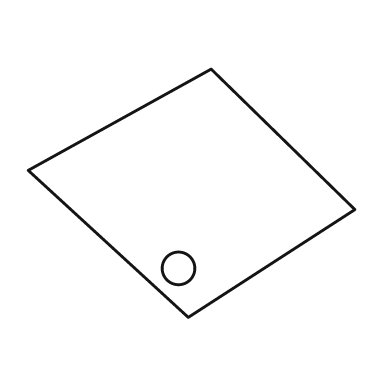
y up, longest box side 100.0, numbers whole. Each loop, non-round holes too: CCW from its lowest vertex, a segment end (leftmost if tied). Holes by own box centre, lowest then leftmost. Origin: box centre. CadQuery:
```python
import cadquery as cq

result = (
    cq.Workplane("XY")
    .moveTo(-1.0, -38.0)
    .lineTo(50.0, -5.0)
    .lineTo(6.0, 38.0)
    .lineTo(-50.0, 7.0)
    .close()
    .moveTo(-4.0, -23.0)
    .circle(5.0)
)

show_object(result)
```